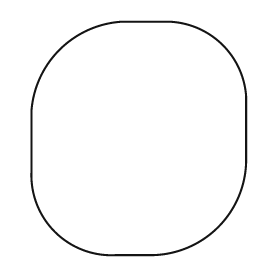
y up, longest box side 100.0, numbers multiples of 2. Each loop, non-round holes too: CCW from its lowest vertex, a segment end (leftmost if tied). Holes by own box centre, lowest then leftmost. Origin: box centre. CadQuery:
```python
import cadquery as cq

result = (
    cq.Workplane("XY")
    .moveTo(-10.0, -50.0)
    .lineTo(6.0, -50.0)
    .threePointArc((34.0, -38.0), (46.0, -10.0))
    .lineTo(46.0, 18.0)
    .threePointArc((36.0, 40.0), (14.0, 50.0))
    .lineTo(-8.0, 50.0)
    .threePointArc((-34.0, 38.0), (-46.0, 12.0))
    .lineTo(-46.0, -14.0)
    .threePointArc((-36.0, -40.0), (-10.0, -50.0))
    .close()
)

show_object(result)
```